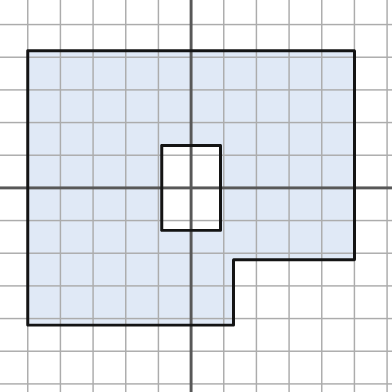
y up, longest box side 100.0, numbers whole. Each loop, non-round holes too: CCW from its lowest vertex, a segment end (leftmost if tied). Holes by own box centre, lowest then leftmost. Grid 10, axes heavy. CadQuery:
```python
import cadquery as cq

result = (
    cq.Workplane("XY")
    .moveTo(-50.0, -42.0)
    .lineTo(13.0, -42.0)
    .lineTo(13.0, -22.0)
    .lineTo(50.0, -22.0)
    .lineTo(50.0, 42.0)
    .lineTo(-50.0, 42.0)
    .close()
    .moveTo(-9.0, -13.0)
    .lineTo(9.0, -13.0)
    .lineTo(9.0, 13.0)
    .lineTo(-9.0, 13.0)
    .close()
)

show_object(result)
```